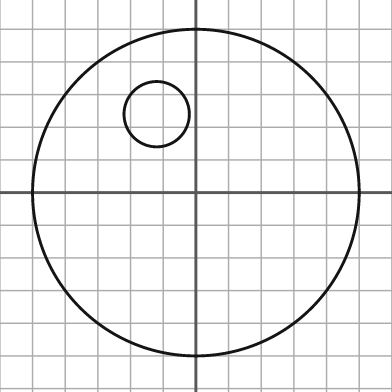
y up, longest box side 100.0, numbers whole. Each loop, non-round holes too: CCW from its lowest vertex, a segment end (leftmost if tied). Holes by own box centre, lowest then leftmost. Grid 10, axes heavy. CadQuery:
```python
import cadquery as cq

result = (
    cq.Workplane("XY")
    .moveTo(0.0, 0.0)
    .circle(50.0)
    .moveTo(-12.0, 24.0)
    .circle(10.0)
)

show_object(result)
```